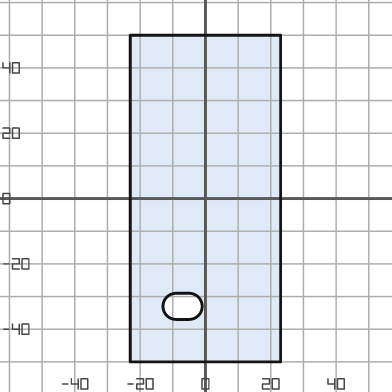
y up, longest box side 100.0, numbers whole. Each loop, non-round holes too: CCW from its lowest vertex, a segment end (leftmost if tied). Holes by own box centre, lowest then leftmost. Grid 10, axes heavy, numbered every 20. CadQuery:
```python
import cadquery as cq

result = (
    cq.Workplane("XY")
    .moveTo(-23.0, -50.0)
    .lineTo(23.0, -50.0)
    .lineTo(23.0, 50.0)
    .lineTo(-23.0, 50.0)
    .close()
    .moveTo(-9.0, -37.0)
    .lineTo(-5.0, -37.0)
    .threePointArc((-1.0, -33.0), (-5.0, -29.0))
    .lineTo(-9.0, -29.0)
    .threePointArc((-13.0, -33.0), (-9.0, -37.0))
    .close()
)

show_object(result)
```